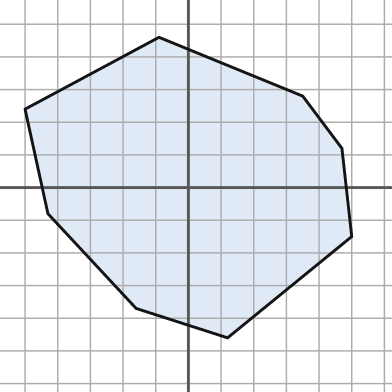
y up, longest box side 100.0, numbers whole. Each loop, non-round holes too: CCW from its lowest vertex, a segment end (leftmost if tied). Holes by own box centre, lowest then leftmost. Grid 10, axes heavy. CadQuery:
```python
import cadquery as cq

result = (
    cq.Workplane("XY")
    .moveTo(12.0, -46.0)
    .lineTo(50.0, -15.0)
    .lineTo(47.0, 12.0)
    .lineTo(35.0, 28.0)
    .lineTo(-9.0, 46.0)
    .lineTo(-50.0, 24.0)
    .lineTo(-43.0, -8.0)
    .lineTo(-16.0, -37.0)
    .close()
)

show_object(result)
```